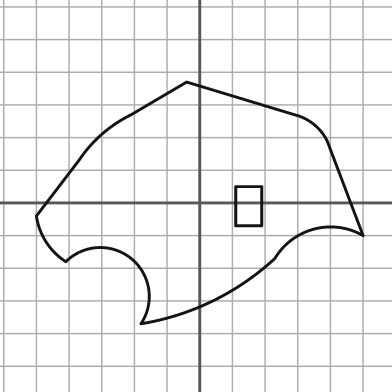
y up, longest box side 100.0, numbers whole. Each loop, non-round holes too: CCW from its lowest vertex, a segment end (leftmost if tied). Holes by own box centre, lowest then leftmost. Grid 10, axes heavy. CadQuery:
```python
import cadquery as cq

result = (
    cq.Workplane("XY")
    .moveTo(-18.0, -37.0)
    .threePointArc((4.0, -30.0), (23.0, -17.0))
    .threePointArc((35.0, -8.0), (50.0, -10.0))
    .lineTo(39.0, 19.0)
    .threePointArc((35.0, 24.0), (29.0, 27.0))
    .lineTo(-4.0, 37.0)
    .lineTo(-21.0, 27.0)
    .threePointArc((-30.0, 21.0), (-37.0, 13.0))
    .lineTo(-50.0, -4.0)
    .threePointArc((-47.0, -12.0), (-41.0, -18.0))
    .threePointArc((-21.0, -17.0), (-18.0, -37.0))
    .close()
    .moveTo(11.0, -7.0)
    .lineTo(19.0, -7.0)
    .lineTo(19.0, 5.0)
    .lineTo(11.0, 5.0)
    .close()
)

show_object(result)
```